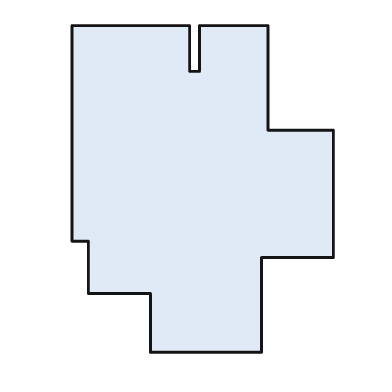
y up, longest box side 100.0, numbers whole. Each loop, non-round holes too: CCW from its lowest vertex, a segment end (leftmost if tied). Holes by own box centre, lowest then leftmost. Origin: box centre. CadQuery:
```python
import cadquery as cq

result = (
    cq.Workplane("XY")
    .moveTo(-16.0, -50.0)
    .lineTo(18.0, -50.0)
    .lineTo(18.0, -21.0)
    .lineTo(40.0, -21.0)
    .lineTo(40.0, 18.0)
    .lineTo(20.0, 18.0)
    .lineTo(20.0, 50.0)
    .lineTo(-1.0, 50.0)
    .lineTo(-1.0, 36.0)
    .lineTo(-4.0, 36.0)
    .lineTo(-4.0, 50.0)
    .lineTo(-40.0, 50.0)
    .lineTo(-40.0, -16.0)
    .lineTo(-35.0, -16.0)
    .lineTo(-35.0, -32.0)
    .lineTo(-16.0, -32.0)
    .close()
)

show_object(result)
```